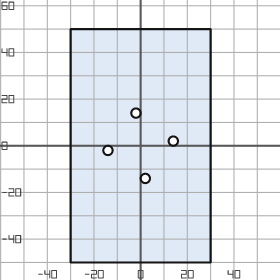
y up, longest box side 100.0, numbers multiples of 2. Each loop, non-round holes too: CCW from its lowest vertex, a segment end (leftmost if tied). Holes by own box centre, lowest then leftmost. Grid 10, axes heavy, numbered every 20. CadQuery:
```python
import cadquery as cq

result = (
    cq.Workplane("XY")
    .moveTo(-30.0, -50.0)
    .lineTo(30.0, -50.0)
    .lineTo(30.0, 50.0)
    .lineTo(-30.0, 50.0)
    .close()
    .moveTo(2.0, -14.0)
    .circle(2.0)
    .moveTo(-14.0, -2.0)
    .circle(2.0)
    .moveTo(14.0, 2.0)
    .circle(2.0)
    .moveTo(-2.0, 14.0)
    .circle(2.0)
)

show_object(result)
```